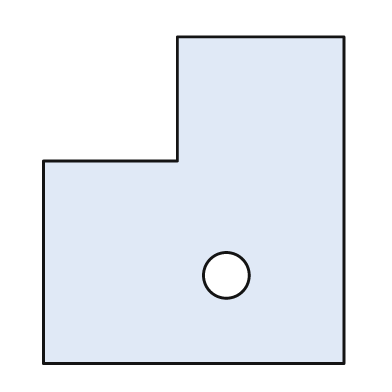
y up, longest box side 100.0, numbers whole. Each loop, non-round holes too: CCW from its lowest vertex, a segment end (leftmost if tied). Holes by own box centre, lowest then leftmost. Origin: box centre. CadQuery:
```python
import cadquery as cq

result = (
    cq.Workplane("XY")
    .moveTo(-46.0, -50.0)
    .lineTo(46.0, -50.0)
    .lineTo(46.0, 50.0)
    .lineTo(-5.0, 50.0)
    .lineTo(-5.0, 12.0)
    .lineTo(-46.0, 12.0)
    .close()
    .moveTo(10.0, -23.0)
    .circle(7.0)
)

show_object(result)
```